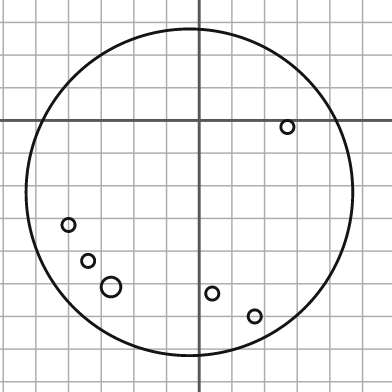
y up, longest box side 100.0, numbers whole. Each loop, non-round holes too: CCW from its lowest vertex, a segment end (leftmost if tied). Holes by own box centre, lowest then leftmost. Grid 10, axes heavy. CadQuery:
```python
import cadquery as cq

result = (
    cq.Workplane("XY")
    .moveTo(-3.0, -22.0)
    .circle(50.0)
    .moveTo(17.0, -60.0)
    .circle(2.0)
    .moveTo(4.0, -53.0)
    .circle(2.0)
    .moveTo(-27.0, -51.0)
    .circle(3.0)
    .moveTo(-34.0, -43.0)
    .circle(2.0)
    .moveTo(-40.0, -32.0)
    .circle(2.0)
    .moveTo(27.0, -2.0)
    .circle(2.0)
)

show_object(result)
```